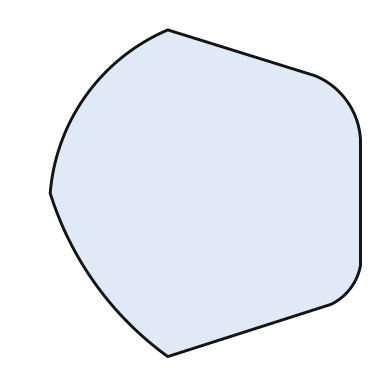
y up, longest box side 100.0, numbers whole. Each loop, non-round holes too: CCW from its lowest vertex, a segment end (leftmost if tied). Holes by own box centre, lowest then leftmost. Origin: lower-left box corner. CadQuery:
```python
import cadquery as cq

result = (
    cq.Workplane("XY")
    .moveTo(36.0, 0.0)
    .lineTo(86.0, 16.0)
    .threePointArc((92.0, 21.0), (95.0, 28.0))
    .lineTo(95.0, 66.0)
    .threePointArc((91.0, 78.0), (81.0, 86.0))
    .lineTo(36.0, 100.0)
    .threePointArc((11.0, 80.0), (0.0, 50.0))
    .threePointArc((14.0, 22.0), (36.0, 0.0))
    .close()
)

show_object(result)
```